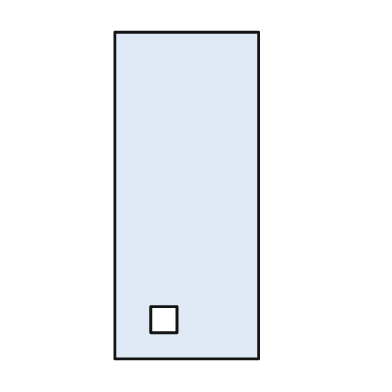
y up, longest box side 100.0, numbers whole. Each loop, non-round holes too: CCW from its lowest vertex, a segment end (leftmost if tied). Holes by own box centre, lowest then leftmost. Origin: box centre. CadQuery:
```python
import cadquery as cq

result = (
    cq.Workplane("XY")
    .moveTo(-22.0, -50.0)
    .lineTo(22.0, -50.0)
    .lineTo(22.0, 50.0)
    .lineTo(-22.0, 50.0)
    .close()
    .moveTo(-11.0, -42.0)
    .lineTo(-3.0, -42.0)
    .lineTo(-3.0, -34.0)
    .lineTo(-11.0, -34.0)
    .close()
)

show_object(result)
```